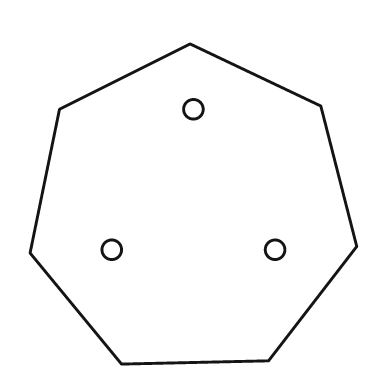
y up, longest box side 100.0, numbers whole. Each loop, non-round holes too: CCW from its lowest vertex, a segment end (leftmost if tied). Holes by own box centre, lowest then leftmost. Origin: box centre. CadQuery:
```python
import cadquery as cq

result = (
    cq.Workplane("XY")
    .moveTo(-22.0, -49.0)
    .lineTo(23.0, -48.0)
    .lineTo(50.0, -13.0)
    .lineTo(39.0, 30.0)
    .lineTo(-1.0, 49.0)
    .lineTo(-41.0, 29.0)
    .lineTo(-50.0, -15.0)
    .close()
    .moveTo(-25.0, -14.0)
    .circle(3.0)
    .moveTo(25.0, -14.0)
    .circle(3.0)
    .moveTo(0.0, 29.0)
    .circle(3.0)
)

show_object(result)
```